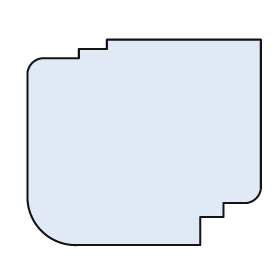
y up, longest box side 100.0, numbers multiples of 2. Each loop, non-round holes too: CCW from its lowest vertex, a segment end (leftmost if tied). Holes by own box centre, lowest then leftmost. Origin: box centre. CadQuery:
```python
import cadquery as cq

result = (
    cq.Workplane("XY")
    .moveTo(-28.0, -44.0)
    .lineTo(24.0, -44.0)
    .lineTo(24.0, -32.0)
    .lineTo(34.0, -32.0)
    .lineTo(34.0, -26.0)
    .lineTo(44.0, -26.0)
    .threePointArc((48.0, -24.0), (50.0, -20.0))
    .lineTo(50.0, 44.0)
    .lineTo(-16.0, 44.0)
    .lineTo(-16.0, 40.0)
    .lineTo(-28.0, 40.0)
    .lineTo(-28.0, 36.0)
    .lineTo(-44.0, 36.0)
    .threePointArc((-48.0, 34.0), (-50.0, 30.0))
    .lineTo(-50.0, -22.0)
    .threePointArc((-44.0, -38.0), (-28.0, -44.0))
    .close()
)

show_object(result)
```